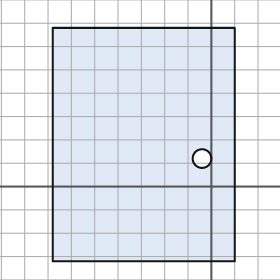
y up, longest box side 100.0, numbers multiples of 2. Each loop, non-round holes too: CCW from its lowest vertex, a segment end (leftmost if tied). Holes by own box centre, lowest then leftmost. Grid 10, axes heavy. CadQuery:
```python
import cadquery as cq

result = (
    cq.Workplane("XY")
    .moveTo(-68.0, -32.0)
    .lineTo(10.0, -32.0)
    .lineTo(10.0, 68.0)
    .lineTo(-68.0, 68.0)
    .close()
    .moveTo(-4.0, 12.0)
    .circle(4.0)
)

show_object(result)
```